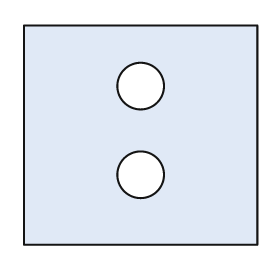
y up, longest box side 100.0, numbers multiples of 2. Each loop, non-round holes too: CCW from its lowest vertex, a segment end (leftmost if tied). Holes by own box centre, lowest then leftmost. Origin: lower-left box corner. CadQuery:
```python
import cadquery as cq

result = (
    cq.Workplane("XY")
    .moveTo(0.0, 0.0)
    .lineTo(100.0, 0.0)
    .lineTo(100.0, 94.0)
    .lineTo(0.0, 94.0)
    .close()
    .moveTo(50.0, 30.0)
    .circle(10.0)
    .moveTo(50.0, 68.0)
    .circle(10.0)
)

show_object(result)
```